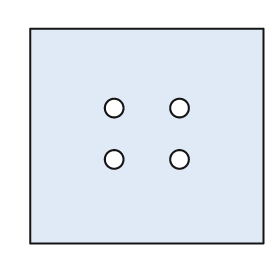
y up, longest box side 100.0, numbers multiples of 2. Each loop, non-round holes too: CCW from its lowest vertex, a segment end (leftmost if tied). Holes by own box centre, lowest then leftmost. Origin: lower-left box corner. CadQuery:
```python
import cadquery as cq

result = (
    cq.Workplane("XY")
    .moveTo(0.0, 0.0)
    .lineTo(100.0, 0.0)
    .lineTo(100.0, 92.0)
    .lineTo(0.0, 92.0)
    .close()
    .moveTo(36.0, 36.0)
    .circle(4.0)
    .moveTo(64.0, 36.0)
    .circle(4.0)
    .moveTo(36.0, 58.0)
    .circle(4.0)
    .moveTo(64.0, 58.0)
    .circle(4.0)
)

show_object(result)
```